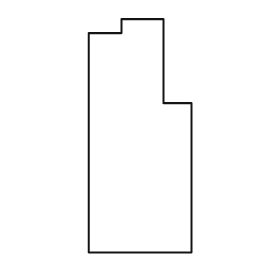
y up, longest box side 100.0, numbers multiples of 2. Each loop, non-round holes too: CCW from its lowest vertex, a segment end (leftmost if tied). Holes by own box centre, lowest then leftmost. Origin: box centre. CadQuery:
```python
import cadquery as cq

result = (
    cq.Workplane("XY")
    .moveTo(-22.0, -50.0)
    .lineTo(22.0, -50.0)
    .lineTo(22.0, 14.0)
    .lineTo(10.0, 14.0)
    .lineTo(10.0, 50.0)
    .lineTo(-8.0, 50.0)
    .lineTo(-8.0, 44.0)
    .lineTo(-22.0, 44.0)
    .close()
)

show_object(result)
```